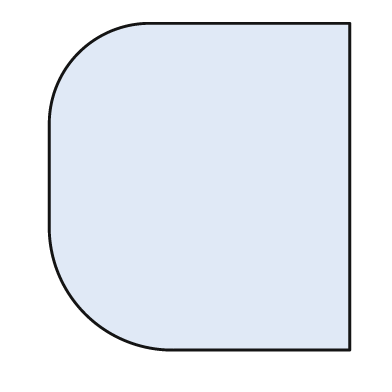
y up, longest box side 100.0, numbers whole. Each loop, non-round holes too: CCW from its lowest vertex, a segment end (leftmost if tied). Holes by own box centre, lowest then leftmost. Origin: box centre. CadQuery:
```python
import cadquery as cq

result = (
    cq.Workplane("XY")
    .moveTo(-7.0, -50.0)
    .lineTo(46.0, -50.0)
    .lineTo(46.0, 50.0)
    .lineTo(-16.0, 50.0)
    .threePointArc((-37.0, 41.0), (-46.0, 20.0))
    .lineTo(-46.0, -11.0)
    .threePointArc((-35.0, -39.0), (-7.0, -50.0))
    .close()
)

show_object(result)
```